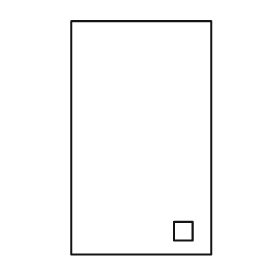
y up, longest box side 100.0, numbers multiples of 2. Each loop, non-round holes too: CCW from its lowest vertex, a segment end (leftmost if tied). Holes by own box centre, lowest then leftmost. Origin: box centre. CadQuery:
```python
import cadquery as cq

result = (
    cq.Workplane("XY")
    .moveTo(-30.0, -50.0)
    .lineTo(30.0, -50.0)
    .lineTo(30.0, 50.0)
    .lineTo(-30.0, 50.0)
    .close()
    .moveTo(14.0, -44.0)
    .lineTo(22.0, -44.0)
    .lineTo(22.0, -36.0)
    .lineTo(14.0, -36.0)
    .close()
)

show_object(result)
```